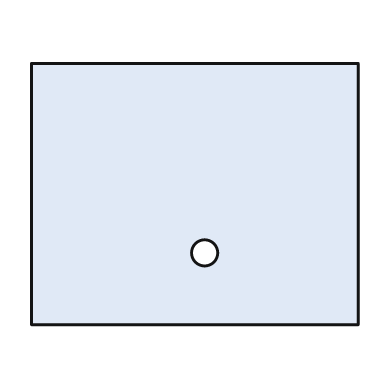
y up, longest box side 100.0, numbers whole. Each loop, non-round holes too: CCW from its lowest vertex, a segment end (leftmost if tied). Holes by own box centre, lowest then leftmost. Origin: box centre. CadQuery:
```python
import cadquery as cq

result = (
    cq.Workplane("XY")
    .moveTo(-50.0, -40.0)
    .lineTo(50.0, -40.0)
    .lineTo(50.0, 40.0)
    .lineTo(-50.0, 40.0)
    .close()
    .moveTo(3.0, -18.0)
    .circle(4.0)
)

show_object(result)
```